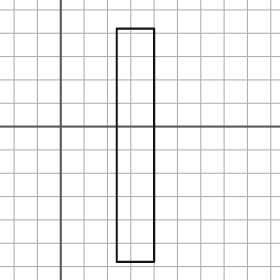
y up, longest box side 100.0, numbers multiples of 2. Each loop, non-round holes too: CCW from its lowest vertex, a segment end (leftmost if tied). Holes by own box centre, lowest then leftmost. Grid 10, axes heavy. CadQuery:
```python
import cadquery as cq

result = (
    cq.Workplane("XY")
    .moveTo(24.0, -58.0)
    .lineTo(40.0, -58.0)
    .lineTo(40.0, 42.0)
    .lineTo(24.0, 42.0)
    .close()
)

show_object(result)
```